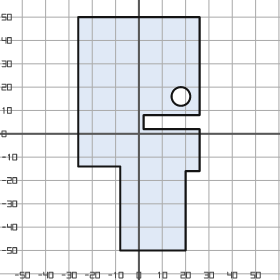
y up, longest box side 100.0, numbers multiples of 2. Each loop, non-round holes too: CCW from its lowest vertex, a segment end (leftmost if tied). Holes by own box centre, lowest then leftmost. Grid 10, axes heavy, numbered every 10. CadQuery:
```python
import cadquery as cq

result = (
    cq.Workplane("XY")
    .moveTo(-8.0, -50.0)
    .lineTo(20.0, -50.0)
    .lineTo(20.0, -16.0)
    .lineTo(26.0, -16.0)
    .lineTo(26.0, 2.0)
    .lineTo(2.0, 2.0)
    .lineTo(2.0, 8.0)
    .lineTo(26.0, 8.0)
    .lineTo(26.0, 50.0)
    .lineTo(-26.0, 50.0)
    .lineTo(-26.0, -14.0)
    .lineTo(-8.0, -14.0)
    .close()
    .moveTo(18.0, 16.0)
    .circle(4.0)
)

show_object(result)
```